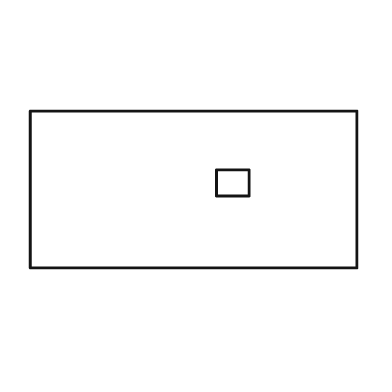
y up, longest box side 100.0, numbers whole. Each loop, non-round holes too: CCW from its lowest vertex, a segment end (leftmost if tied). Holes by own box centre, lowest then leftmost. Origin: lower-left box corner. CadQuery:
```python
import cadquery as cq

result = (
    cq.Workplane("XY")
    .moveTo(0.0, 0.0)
    .lineTo(100.0, 0.0)
    .lineTo(100.0, 48.0)
    .lineTo(0.0, 48.0)
    .close()
    .moveTo(57.0, 22.0)
    .lineTo(67.0, 22.0)
    .lineTo(67.0, 30.0)
    .lineTo(57.0, 30.0)
    .close()
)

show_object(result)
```